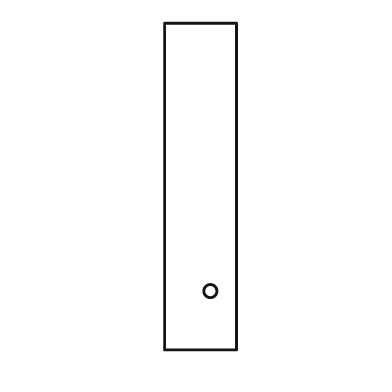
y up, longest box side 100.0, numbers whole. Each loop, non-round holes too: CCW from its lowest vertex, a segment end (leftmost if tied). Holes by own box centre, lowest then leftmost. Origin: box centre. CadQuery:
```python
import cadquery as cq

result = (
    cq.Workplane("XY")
    .moveTo(-11.0, -50.0)
    .lineTo(11.0, -50.0)
    .lineTo(11.0, 50.0)
    .lineTo(-11.0, 50.0)
    .close()
    .moveTo(3.0, -32.0)
    .circle(2.0)
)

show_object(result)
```